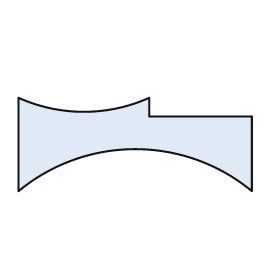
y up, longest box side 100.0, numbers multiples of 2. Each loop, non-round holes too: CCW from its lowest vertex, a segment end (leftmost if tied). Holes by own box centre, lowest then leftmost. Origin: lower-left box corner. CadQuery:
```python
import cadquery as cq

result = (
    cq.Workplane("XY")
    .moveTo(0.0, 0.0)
    .threePointArc((50.0, 18.0), (100.0, 0.0))
    .lineTo(100.0, 32.0)
    .lineTo(56.0, 32.0)
    .lineTo(56.0, 40.0)
    .threePointArc((28.0, 34.0), (0.0, 40.0))
    .close()
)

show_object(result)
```